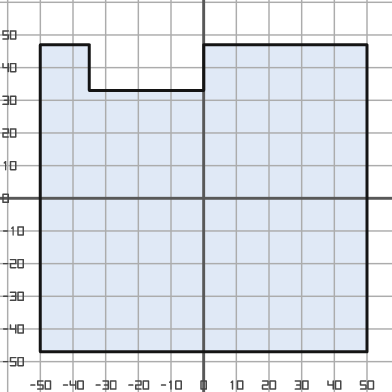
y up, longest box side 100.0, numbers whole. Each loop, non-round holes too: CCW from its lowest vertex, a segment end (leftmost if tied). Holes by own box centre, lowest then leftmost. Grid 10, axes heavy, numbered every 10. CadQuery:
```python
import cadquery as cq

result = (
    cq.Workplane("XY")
    .moveTo(-50.0, -47.0)
    .lineTo(50.0, -47.0)
    .lineTo(50.0, 47.0)
    .lineTo(0.0, 47.0)
    .lineTo(0.0, 33.0)
    .lineTo(-35.0, 33.0)
    .lineTo(-35.0, 47.0)
    .lineTo(-50.0, 47.0)
    .close()
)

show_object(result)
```